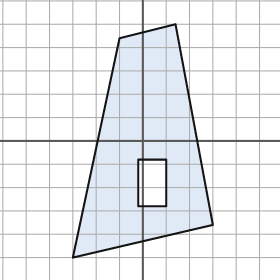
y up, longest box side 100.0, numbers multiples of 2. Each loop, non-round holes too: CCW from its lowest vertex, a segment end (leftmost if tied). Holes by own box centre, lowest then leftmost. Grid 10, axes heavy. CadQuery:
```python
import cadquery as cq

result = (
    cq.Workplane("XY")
    .moveTo(-30.0, -50.0)
    .lineTo(30.0, -36.0)
    .lineTo(14.0, 50.0)
    .lineTo(-10.0, 44.0)
    .close()
    .moveTo(-2.0, -28.0)
    .lineTo(10.0, -28.0)
    .lineTo(10.0, -8.0)
    .lineTo(-2.0, -8.0)
    .close()
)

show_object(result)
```